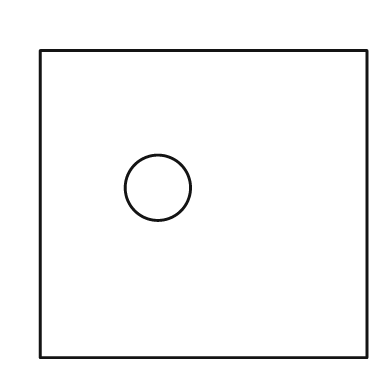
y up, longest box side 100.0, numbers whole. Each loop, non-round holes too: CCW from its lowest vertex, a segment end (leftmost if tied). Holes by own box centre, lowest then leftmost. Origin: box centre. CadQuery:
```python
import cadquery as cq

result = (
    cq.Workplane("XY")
    .moveTo(-50.0, -47.0)
    .lineTo(50.0, -47.0)
    .lineTo(50.0, 47.0)
    .lineTo(-50.0, 47.0)
    .close()
    .moveTo(-14.0, 5.0)
    .circle(10.0)
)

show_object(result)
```